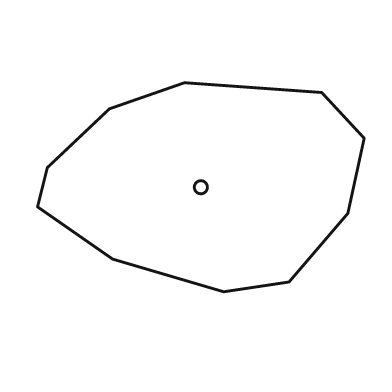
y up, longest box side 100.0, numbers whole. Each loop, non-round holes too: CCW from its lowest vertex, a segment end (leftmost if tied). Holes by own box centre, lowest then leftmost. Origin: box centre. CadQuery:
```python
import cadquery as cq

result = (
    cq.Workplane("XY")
    .moveTo(7.0, -32.0)
    .lineTo(27.0, -29.0)
    .lineTo(45.0, -8.0)
    .lineTo(50.0, 15.0)
    .lineTo(37.0, 29.0)
    .lineTo(-5.0, 32.0)
    .lineTo(-28.0, 24.0)
    .lineTo(-47.0, 6.0)
    .lineTo(-50.0, -6.0)
    .lineTo(-27.0, -22.0)
    .close()
    .moveTo(0.0, 0.0)
    .circle(2.0)
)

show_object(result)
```